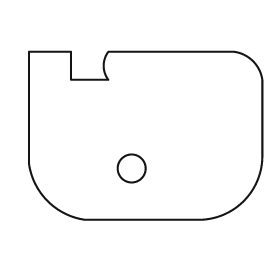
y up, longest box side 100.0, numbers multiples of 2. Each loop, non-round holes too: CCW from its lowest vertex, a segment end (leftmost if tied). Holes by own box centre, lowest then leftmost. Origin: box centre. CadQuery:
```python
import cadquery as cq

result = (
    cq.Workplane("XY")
    .moveTo(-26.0, -36.0)
    .lineTo(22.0, -36.0)
    .threePointArc((42.0, -28.0), (50.0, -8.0))
    .lineTo(50.0, 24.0)
    .threePointArc((46.0, 32.0), (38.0, 36.0))
    .lineTo(-16.0, 36.0)
    .threePointArc((-18.0, 30.0), (-16.0, 24.0))
    .lineTo(-32.0, 24.0)
    .lineTo(-32.0, 36.0)
    .lineTo(-50.0, 36.0)
    .lineTo(-50.0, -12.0)
    .threePointArc((-42.0, -28.0), (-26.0, -36.0))
    .close()
    .moveTo(-6.0, -14.0)
    .circle(6.0)
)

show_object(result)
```